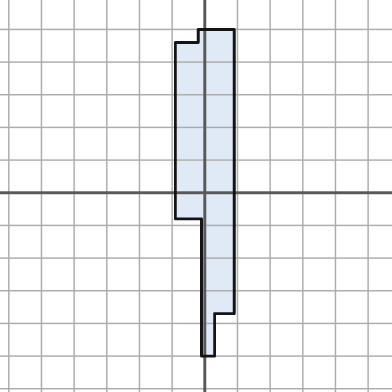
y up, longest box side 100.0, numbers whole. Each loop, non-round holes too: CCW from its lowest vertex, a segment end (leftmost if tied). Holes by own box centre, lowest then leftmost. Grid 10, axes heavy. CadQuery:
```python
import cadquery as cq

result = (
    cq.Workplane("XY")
    .moveTo(-1.0, -50.0)
    .lineTo(3.0, -50.0)
    .lineTo(3.0, -37.0)
    .lineTo(9.0, -37.0)
    .lineTo(9.0, 50.0)
    .lineTo(-2.0, 50.0)
    .lineTo(-2.0, 46.0)
    .lineTo(-9.0, 46.0)
    .lineTo(-9.0, -8.0)
    .lineTo(-1.0, -8.0)
    .close()
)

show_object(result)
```